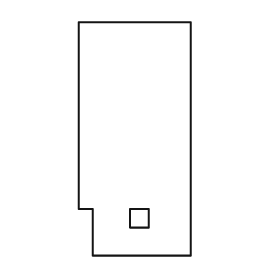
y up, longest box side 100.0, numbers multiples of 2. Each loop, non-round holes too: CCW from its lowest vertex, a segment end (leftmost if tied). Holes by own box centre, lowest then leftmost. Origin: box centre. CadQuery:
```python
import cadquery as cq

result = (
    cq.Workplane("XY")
    .moveTo(-18.0, -50.0)
    .lineTo(24.0, -50.0)
    .lineTo(24.0, 50.0)
    .lineTo(-24.0, 50.0)
    .lineTo(-24.0, -30.0)
    .lineTo(-18.0, -30.0)
    .close()
    .moveTo(-2.0, -38.0)
    .lineTo(6.0, -38.0)
    .lineTo(6.0, -30.0)
    .lineTo(-2.0, -30.0)
    .close()
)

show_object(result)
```